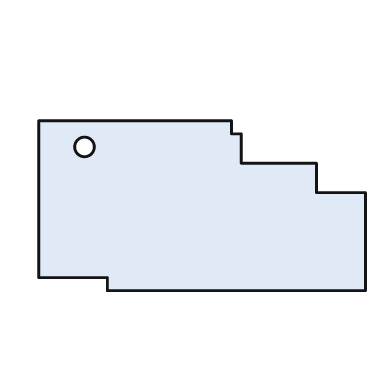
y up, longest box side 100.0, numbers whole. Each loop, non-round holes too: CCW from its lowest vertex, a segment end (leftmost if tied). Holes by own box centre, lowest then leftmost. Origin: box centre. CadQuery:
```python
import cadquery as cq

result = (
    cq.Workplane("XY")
    .moveTo(-29.0, -26.0)
    .lineTo(50.0, -26.0)
    .lineTo(50.0, 4.0)
    .lineTo(35.0, 4.0)
    .lineTo(35.0, 13.0)
    .lineTo(12.0, 13.0)
    .lineTo(12.0, 22.0)
    .lineTo(9.0, 22.0)
    .lineTo(9.0, 26.0)
    .lineTo(-50.0, 26.0)
    .lineTo(-50.0, -22.0)
    .lineTo(-29.0, -22.0)
    .close()
    .moveTo(-36.0, 18.0)
    .circle(3.0)
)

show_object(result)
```